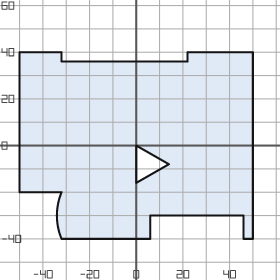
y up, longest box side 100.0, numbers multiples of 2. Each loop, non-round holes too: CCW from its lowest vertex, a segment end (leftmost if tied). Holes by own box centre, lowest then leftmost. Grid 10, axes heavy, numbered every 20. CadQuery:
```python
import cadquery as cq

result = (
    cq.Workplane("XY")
    .moveTo(-32.0, -40.0)
    .lineTo(6.0, -40.0)
    .lineTo(6.0, -30.0)
    .lineTo(46.0, -30.0)
    .lineTo(46.0, -40.0)
    .lineTo(50.0, -40.0)
    .lineTo(50.0, 40.0)
    .lineTo(22.0, 40.0)
    .lineTo(22.0, 36.0)
    .lineTo(-32.0, 36.0)
    .lineTo(-32.0, 40.0)
    .lineTo(-50.0, 40.0)
    .lineTo(-50.0, -20.0)
    .lineTo(-32.0, -20.0)
    .threePointArc((-34.0, -30.0), (-32.0, -40.0))
    .close()
    .moveTo(0.0, -16.0)
    .lineTo(14.0, -8.0)
    .lineTo(0.0, 0.0)
    .close()
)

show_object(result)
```